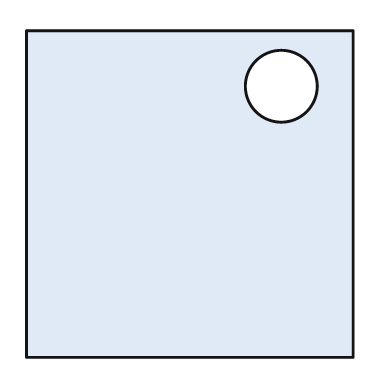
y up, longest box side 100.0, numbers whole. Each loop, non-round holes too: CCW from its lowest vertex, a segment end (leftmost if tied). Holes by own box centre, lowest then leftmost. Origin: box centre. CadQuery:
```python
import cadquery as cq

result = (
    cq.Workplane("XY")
    .moveTo(-50.0, -50.0)
    .lineTo(50.0, -50.0)
    .lineTo(50.0, 50.0)
    .lineTo(-50.0, 50.0)
    .close()
    .moveTo(28.0, 33.0)
    .circle(11.0)
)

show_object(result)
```